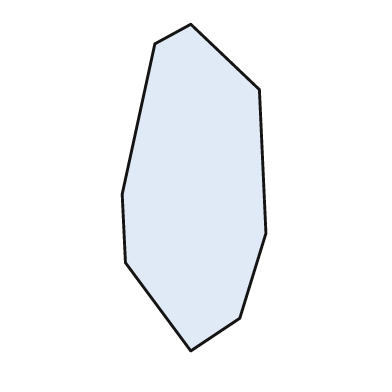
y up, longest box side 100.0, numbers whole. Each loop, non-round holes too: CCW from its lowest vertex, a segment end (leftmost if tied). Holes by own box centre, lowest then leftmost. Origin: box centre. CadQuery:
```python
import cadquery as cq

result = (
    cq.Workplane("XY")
    .moveTo(-1.0, -50.0)
    .lineTo(14.0, -40.0)
    .lineTo(22.0, -14.0)
    .lineTo(20.0, 30.0)
    .lineTo(-1.0, 50.0)
    .lineTo(-12.0, 44.0)
    .lineTo(-22.0, -2.0)
    .lineTo(-21.0, -23.0)
    .close()
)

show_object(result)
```